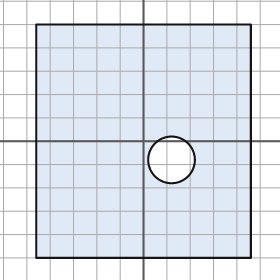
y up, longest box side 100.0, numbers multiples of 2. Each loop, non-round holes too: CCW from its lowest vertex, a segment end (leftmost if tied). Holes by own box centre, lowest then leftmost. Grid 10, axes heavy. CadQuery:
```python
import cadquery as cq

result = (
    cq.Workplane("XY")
    .moveTo(-46.0, -50.0)
    .lineTo(46.0, -50.0)
    .lineTo(46.0, 50.0)
    .lineTo(-46.0, 50.0)
    .close()
    .moveTo(12.0, -8.0)
    .circle(10.0)
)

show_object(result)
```